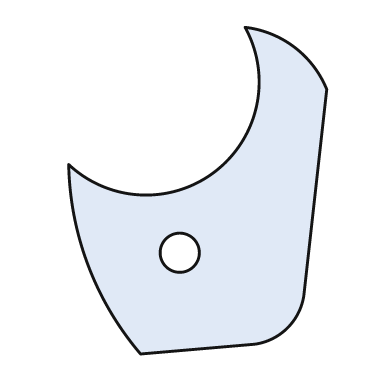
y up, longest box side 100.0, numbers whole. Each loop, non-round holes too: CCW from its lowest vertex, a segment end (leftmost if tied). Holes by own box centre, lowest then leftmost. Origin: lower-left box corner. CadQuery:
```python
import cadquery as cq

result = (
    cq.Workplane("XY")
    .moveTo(22.0, 0.0)
    .lineTo(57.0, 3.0)
    .threePointArc((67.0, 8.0), (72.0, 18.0))
    .lineTo(79.0, 81.0)
    .threePointArc((69.0, 94.0), (54.0, 100.0))
    .threePointArc((45.0, 56.0), (0.0, 58.0))
    .threePointArc((6.0, 27.0), (22.0, 0.0))
    .close()
    .moveTo(34.0, 31.0)
    .circle(6.0)
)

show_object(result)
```